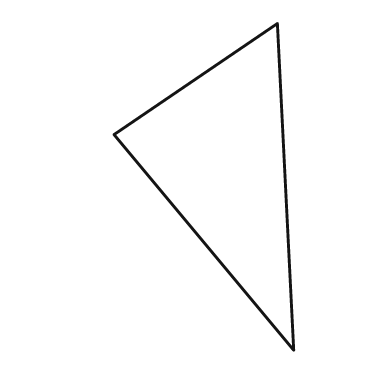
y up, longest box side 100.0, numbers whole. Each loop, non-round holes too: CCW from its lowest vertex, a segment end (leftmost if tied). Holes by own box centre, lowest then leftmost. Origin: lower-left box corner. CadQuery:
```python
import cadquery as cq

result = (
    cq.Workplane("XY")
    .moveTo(55.0, 0.0)
    .lineTo(50.0, 100.0)
    .lineTo(0.0, 66.0)
    .close()
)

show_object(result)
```